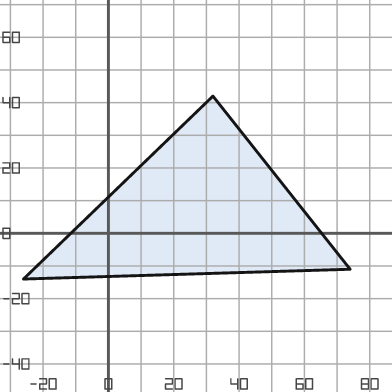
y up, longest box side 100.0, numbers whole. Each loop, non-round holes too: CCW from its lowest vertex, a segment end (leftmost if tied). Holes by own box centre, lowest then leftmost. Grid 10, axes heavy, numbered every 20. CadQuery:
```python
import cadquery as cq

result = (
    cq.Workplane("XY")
    .moveTo(-26.0, -14.0)
    .lineTo(74.0, -11.0)
    .lineTo(32.0, 42.0)
    .close()
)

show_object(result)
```